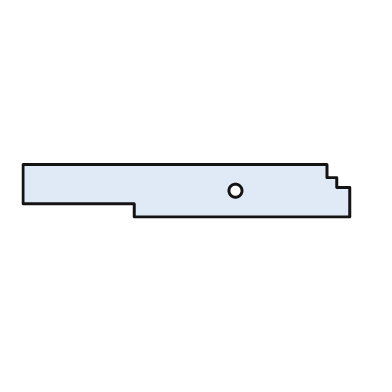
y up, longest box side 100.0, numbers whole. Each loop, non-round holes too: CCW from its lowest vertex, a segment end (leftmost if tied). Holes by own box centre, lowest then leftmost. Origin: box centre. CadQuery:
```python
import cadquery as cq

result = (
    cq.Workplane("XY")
    .moveTo(-16.0, -8.0)
    .lineTo(50.0, -8.0)
    .lineTo(50.0, 1.0)
    .lineTo(46.0, 1.0)
    .lineTo(46.0, 4.0)
    .lineTo(43.0, 4.0)
    .lineTo(43.0, 8.0)
    .lineTo(-50.0, 8.0)
    .lineTo(-50.0, -4.0)
    .lineTo(-16.0, -4.0)
    .close()
    .moveTo(15.0, 0.0)
    .circle(2.0)
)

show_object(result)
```